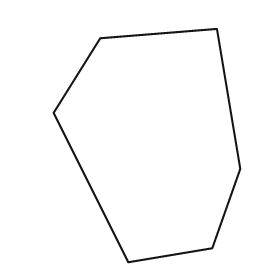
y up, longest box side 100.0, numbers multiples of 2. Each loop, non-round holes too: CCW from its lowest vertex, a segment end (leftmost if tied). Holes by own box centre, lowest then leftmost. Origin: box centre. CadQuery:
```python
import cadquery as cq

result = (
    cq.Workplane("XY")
    .moveTo(-8.0, -50.0)
    .lineTo(28.0, -44.0)
    .lineTo(40.0, -10.0)
    .lineTo(30.0, 50.0)
    .lineTo(-20.0, 46.0)
    .lineTo(-40.0, 14.0)
    .close()
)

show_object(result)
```